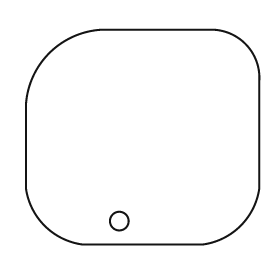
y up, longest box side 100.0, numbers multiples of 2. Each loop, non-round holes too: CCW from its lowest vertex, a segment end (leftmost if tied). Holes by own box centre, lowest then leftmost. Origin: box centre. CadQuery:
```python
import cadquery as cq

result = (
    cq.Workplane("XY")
    .moveTo(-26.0, -46.0)
    .lineTo(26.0, -46.0)
    .threePointArc((42.0, -38.0), (50.0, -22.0))
    .lineTo(50.0, 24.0)
    .threePointArc((44.0, 40.0), (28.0, 46.0))
    .lineTo(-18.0, 46.0)
    .threePointArc((-40.0, 36.0), (-50.0, 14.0))
    .lineTo(-50.0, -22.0)
    .threePointArc((-42.0, -38.0), (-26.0, -46.0))
    .close()
    .moveTo(-10.0, -36.0)
    .circle(4.0)
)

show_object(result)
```